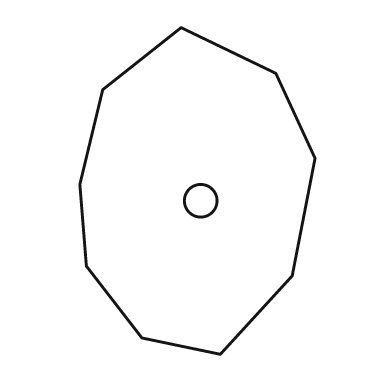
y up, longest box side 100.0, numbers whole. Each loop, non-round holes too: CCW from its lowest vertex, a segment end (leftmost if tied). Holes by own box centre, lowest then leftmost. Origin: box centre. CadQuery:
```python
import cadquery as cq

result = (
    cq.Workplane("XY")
    .moveTo(7.0, -50.0)
    .lineTo(29.0, -26.0)
    .lineTo(36.0, 10.0)
    .lineTo(24.0, 36.0)
    .lineTo(-5.0, 50.0)
    .lineTo(-29.0, 31.0)
    .lineTo(-36.0, 2.0)
    .lineTo(-34.0, -23.0)
    .lineTo(-17.0, -45.0)
    .close()
    .moveTo(1.0, -3.0)
    .circle(5.0)
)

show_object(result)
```